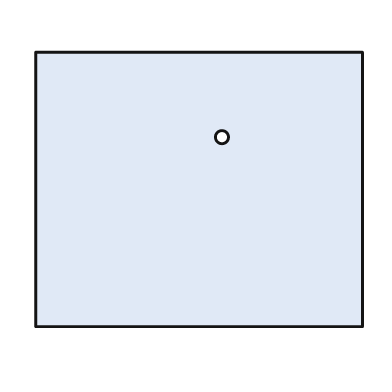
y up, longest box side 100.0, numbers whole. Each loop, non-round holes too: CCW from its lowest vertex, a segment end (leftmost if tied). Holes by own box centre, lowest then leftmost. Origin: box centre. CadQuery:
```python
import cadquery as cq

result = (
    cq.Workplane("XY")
    .moveTo(-50.0, -42.0)
    .lineTo(50.0, -42.0)
    .lineTo(50.0, 42.0)
    .lineTo(-50.0, 42.0)
    .close()
    .moveTo(7.0, 16.0)
    .circle(2.0)
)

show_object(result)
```